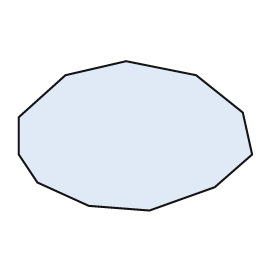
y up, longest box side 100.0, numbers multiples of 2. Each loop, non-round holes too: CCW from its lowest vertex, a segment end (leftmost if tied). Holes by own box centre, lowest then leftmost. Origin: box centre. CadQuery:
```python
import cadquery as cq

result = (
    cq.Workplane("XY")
    .moveTo(6.0, -32.0)
    .lineTo(34.0, -22.0)
    .lineTo(50.0, -8.0)
    .lineTo(46.0, 10.0)
    .lineTo(26.0, 26.0)
    .lineTo(-4.0, 32.0)
    .lineTo(-30.0, 26.0)
    .lineTo(-50.0, 8.0)
    .lineTo(-50.0, -8.0)
    .lineTo(-42.0, -20.0)
    .lineTo(-20.0, -30.0)
    .close()
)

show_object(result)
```